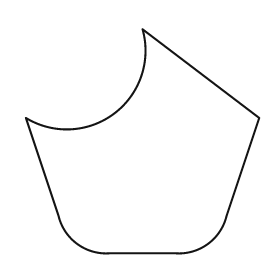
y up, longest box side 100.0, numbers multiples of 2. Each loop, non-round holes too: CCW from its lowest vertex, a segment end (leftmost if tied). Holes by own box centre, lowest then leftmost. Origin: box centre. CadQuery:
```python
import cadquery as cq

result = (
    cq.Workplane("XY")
    .moveTo(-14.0, -48.0)
    .lineTo(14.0, -48.0)
    .threePointArc((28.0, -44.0), (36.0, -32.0))
    .lineTo(50.0, 10.0)
    .lineTo(0.0, 48.0)
    .threePointArc((-12.0, 12.0), (-50.0, 10.0))
    .lineTo(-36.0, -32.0)
    .threePointArc((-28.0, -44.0), (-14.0, -48.0))
    .close()
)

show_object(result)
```